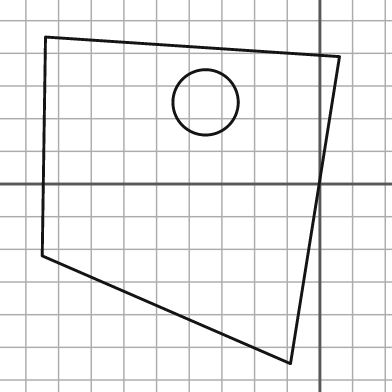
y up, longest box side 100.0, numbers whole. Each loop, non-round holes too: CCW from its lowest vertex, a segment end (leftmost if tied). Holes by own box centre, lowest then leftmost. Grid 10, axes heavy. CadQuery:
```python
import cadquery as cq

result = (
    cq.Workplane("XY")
    .moveTo(-9.0, -55.0)
    .lineTo(6.0, 39.0)
    .lineTo(-84.0, 45.0)
    .lineTo(-85.0, -22.0)
    .close()
    .moveTo(-35.0, 25.0)
    .circle(10.0)
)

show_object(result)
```